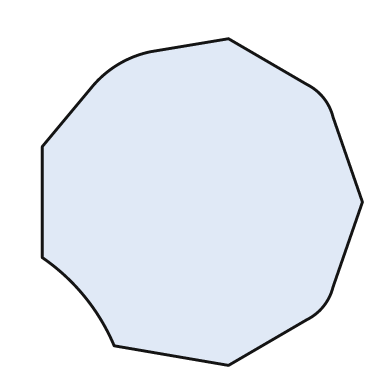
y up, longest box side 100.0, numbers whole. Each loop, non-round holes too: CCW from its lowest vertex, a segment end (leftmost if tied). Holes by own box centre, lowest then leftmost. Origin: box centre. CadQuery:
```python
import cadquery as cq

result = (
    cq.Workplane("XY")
    .moveTo(8.0, -50.0)
    .lineTo(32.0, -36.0)
    .threePointArc((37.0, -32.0), (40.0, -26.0))
    .lineTo(49.0, 0.0)
    .lineTo(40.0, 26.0)
    .threePointArc((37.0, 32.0), (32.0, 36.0))
    .lineTo(8.0, 50.0)
    .lineTo(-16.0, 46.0)
    .threePointArc((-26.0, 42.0), (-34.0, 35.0))
    .lineTo(-49.0, 17.0)
    .lineTo(-49.0, -17.0)
    .threePointArc((-36.0, -29.0), (-27.0, -44.0))
    .close()
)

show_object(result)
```